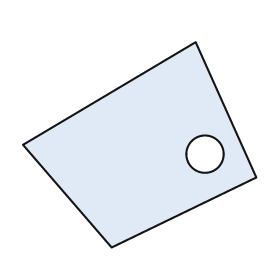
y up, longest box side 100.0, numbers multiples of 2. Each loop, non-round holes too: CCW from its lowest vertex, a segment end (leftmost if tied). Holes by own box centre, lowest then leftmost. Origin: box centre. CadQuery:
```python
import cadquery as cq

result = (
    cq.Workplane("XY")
    .moveTo(-12.0, -44.0)
    .lineTo(50.0, -14.0)
    .lineTo(24.0, 44.0)
    .lineTo(-50.0, 0.0)
    .close()
    .moveTo(28.0, -4.0)
    .circle(8.0)
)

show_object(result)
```